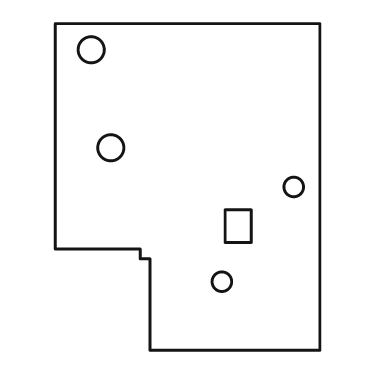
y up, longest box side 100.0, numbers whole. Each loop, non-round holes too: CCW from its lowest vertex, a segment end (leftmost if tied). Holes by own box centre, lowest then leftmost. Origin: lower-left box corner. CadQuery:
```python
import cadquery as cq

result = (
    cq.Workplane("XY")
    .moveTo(29.0, 0.0)
    .lineTo(81.0, 0.0)
    .lineTo(81.0, 100.0)
    .lineTo(0.0, 100.0)
    .lineTo(0.0, 31.0)
    .lineTo(26.0, 31.0)
    .lineTo(26.0, 28.0)
    .lineTo(29.0, 28.0)
    .close()
    .moveTo(51.0, 21.0)
    .circle(3.0)
    .moveTo(52.0, 33.0)
    .lineTo(60.0, 33.0)
    .lineTo(60.0, 43.0)
    .lineTo(52.0, 43.0)
    .close()
    .moveTo(73.0, 50.0)
    .circle(3.0)
    .moveTo(17.0, 62.0)
    .circle(4.0)
    .moveTo(11.0, 92.0)
    .circle(4.0)
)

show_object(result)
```